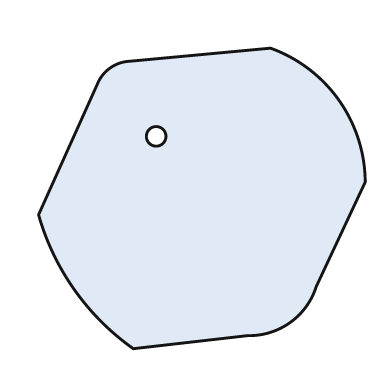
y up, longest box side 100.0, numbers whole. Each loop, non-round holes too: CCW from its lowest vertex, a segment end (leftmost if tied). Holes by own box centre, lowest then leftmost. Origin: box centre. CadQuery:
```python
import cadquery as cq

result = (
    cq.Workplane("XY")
    .moveTo(-21.0, -46.0)
    .lineTo(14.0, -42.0)
    .threePointArc((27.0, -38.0), (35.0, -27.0))
    .lineTo(50.0, 5.0)
    .threePointArc((42.0, 30.0), (21.0, 46.0))
    .lineTo(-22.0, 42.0)
    .threePointArc((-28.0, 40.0), (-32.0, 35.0))
    .lineTo(-50.0, -5.0)
    .threePointArc((-39.0, -28.0), (-21.0, -46.0))
    .close()
    .moveTo(-14.0, 19.0)
    .circle(3.0)
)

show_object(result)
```